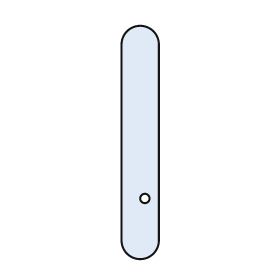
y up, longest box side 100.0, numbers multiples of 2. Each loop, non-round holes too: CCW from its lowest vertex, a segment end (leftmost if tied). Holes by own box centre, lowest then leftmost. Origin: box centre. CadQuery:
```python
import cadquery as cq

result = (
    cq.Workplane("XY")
    .moveTo(-8.0, -42.0)
    .threePointArc((0.0, -50.0), (8.0, -42.0))
    .lineTo(8.0, 42.0)
    .threePointArc((0.0, 50.0), (-8.0, 42.0))
    .close()
    .moveTo(2.0, -24.0)
    .circle(2.0)
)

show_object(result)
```